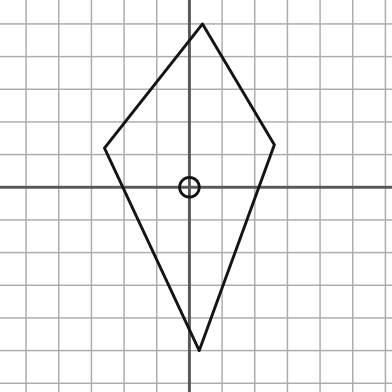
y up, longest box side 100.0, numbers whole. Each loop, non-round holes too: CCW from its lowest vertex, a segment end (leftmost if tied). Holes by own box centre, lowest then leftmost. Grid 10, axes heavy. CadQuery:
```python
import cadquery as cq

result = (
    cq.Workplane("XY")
    .moveTo(3.0, -50.0)
    .lineTo(26.0, 13.0)
    .lineTo(4.0, 50.0)
    .lineTo(-26.0, 12.0)
    .close()
    .moveTo(0.0, 0.0)
    .circle(3.0)
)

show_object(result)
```